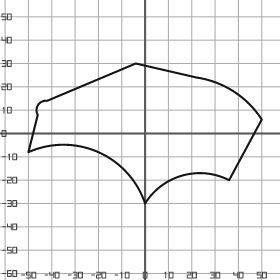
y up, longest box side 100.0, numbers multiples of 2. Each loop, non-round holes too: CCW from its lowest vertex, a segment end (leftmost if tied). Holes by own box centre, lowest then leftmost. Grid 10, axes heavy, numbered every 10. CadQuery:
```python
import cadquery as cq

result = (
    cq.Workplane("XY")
    .moveTo(0.0, -30.0)
    .threePointArc((16.0, -18.0), (36.0, -20.0))
    .lineTo(50.0, 6.0)
    .threePointArc((38.0, 18.0), (22.0, 24.0))
    .lineTo(-4.0, 30.0)
    .lineTo(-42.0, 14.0)
    .threePointArc((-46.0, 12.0), (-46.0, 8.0))
    .lineTo(-50.0, -8.0)
    .threePointArc((-20.0, -8.0), (0.0, -30.0))
    .close()
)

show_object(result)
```